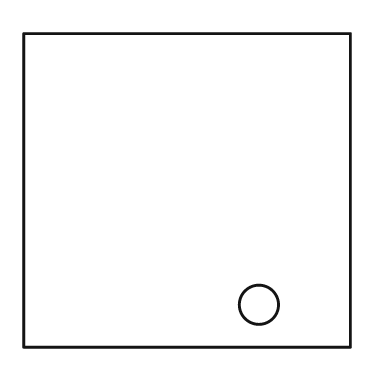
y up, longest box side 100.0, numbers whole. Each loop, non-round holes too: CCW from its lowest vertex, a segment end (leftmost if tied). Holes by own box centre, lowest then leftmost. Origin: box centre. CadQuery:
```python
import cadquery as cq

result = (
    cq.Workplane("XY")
    .moveTo(-50.0, -48.0)
    .lineTo(50.0, -48.0)
    .lineTo(50.0, 48.0)
    .lineTo(-50.0, 48.0)
    .close()
    .moveTo(22.0, -35.0)
    .circle(6.0)
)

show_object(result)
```